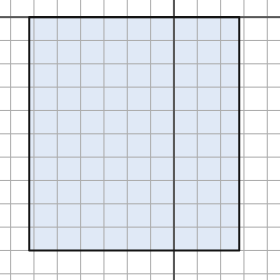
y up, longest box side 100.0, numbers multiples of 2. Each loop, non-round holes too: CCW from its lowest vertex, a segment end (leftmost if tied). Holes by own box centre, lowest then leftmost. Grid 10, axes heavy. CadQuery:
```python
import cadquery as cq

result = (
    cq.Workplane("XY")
    .moveTo(-62.0, -100.0)
    .lineTo(28.0, -100.0)
    .lineTo(28.0, 0.0)
    .lineTo(-62.0, 0.0)
    .close()
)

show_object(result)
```